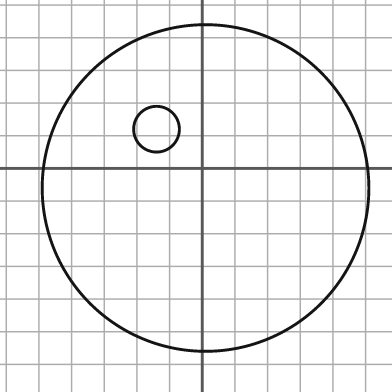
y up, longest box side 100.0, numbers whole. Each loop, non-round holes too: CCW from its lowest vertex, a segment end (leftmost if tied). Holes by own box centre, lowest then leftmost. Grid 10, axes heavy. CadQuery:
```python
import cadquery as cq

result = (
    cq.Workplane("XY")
    .moveTo(1.0, -6.0)
    .circle(50.0)
    .moveTo(-14.0, 12.0)
    .circle(7.0)
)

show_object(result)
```